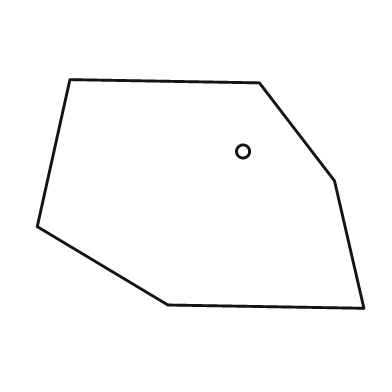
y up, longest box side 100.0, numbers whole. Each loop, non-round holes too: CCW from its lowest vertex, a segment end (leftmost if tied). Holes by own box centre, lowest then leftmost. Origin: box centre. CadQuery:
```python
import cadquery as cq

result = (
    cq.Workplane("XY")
    .moveTo(50.0, -35.0)
    .lineTo(41.0, 4.0)
    .lineTo(18.0, 34.0)
    .lineTo(-40.0, 35.0)
    .lineTo(-50.0, -10.0)
    .lineTo(-10.0, -34.0)
    .close()
    .moveTo(13.0, 13.0)
    .circle(2.0)
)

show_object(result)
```